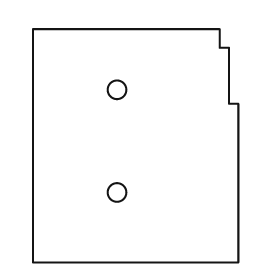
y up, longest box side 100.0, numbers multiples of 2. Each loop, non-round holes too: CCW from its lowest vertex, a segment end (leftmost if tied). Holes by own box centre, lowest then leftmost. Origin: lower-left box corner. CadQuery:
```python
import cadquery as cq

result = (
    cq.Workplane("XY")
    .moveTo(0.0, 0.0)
    .lineTo(88.0, 0.0)
    .lineTo(88.0, 68.0)
    .lineTo(84.0, 68.0)
    .lineTo(84.0, 92.0)
    .lineTo(80.0, 92.0)
    .lineTo(80.0, 100.0)
    .lineTo(0.0, 100.0)
    .close()
    .moveTo(36.0, 30.0)
    .circle(4.0)
    .moveTo(36.0, 74.0)
    .circle(4.0)
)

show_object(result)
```